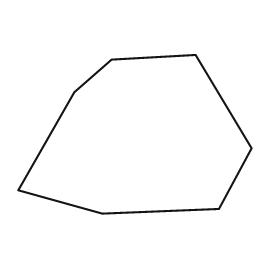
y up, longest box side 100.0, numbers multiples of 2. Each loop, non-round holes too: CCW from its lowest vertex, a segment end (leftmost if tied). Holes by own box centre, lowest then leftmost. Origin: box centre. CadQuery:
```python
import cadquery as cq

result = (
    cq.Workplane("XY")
    .moveTo(-14.0, -34.0)
    .lineTo(36.0, -32.0)
    .lineTo(50.0, -6.0)
    .lineTo(26.0, 34.0)
    .lineTo(-10.0, 32.0)
    .lineTo(-26.0, 18.0)
    .lineTo(-50.0, -24.0)
    .close()
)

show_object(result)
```